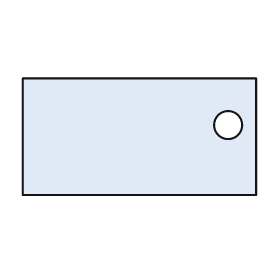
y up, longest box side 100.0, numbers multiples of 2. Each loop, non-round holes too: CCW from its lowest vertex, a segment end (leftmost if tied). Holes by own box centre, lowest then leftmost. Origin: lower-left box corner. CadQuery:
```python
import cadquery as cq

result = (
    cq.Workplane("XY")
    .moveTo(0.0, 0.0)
    .lineTo(100.0, 0.0)
    .lineTo(100.0, 50.0)
    .lineTo(0.0, 50.0)
    .close()
    .moveTo(88.0, 30.0)
    .circle(6.0)
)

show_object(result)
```